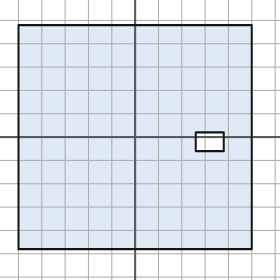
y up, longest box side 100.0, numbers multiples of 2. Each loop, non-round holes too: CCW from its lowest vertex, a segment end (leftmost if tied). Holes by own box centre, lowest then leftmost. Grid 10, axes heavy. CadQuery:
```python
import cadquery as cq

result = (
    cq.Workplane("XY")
    .moveTo(-50.0, -48.0)
    .lineTo(50.0, -48.0)
    .lineTo(50.0, 48.0)
    .lineTo(-50.0, 48.0)
    .close()
    .moveTo(26.0, -6.0)
    .lineTo(38.0, -6.0)
    .lineTo(38.0, 2.0)
    .lineTo(26.0, 2.0)
    .close()
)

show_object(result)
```